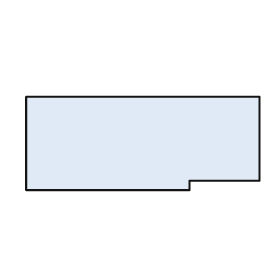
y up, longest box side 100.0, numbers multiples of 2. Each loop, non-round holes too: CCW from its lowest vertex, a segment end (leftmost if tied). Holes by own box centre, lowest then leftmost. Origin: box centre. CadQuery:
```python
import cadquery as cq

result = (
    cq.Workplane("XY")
    .moveTo(-50.0, -20.0)
    .lineTo(20.0, -20.0)
    .lineTo(20.0, -16.0)
    .lineTo(50.0, -16.0)
    .lineTo(50.0, 20.0)
    .lineTo(-50.0, 20.0)
    .close()
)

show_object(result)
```